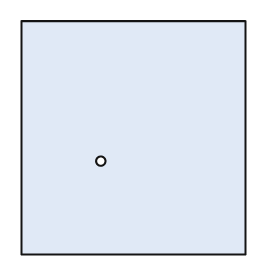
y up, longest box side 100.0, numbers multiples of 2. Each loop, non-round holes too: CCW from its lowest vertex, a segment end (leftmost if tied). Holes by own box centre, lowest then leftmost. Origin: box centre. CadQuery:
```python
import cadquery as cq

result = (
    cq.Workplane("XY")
    .moveTo(-48.0, -50.0)
    .lineTo(48.0, -50.0)
    .lineTo(48.0, 50.0)
    .lineTo(-48.0, 50.0)
    .close()
    .moveTo(-14.0, -10.0)
    .circle(2.0)
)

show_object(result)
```